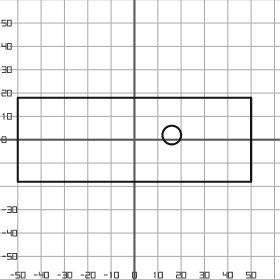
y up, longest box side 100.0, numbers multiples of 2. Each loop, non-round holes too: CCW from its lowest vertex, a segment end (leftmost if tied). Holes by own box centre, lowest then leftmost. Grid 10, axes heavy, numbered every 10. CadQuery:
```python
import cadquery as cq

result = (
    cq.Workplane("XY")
    .moveTo(-50.0, -18.0)
    .lineTo(50.0, -18.0)
    .lineTo(50.0, 18.0)
    .lineTo(-50.0, 18.0)
    .close()
    .moveTo(16.0, 2.0)
    .circle(4.0)
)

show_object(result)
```